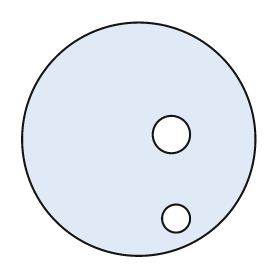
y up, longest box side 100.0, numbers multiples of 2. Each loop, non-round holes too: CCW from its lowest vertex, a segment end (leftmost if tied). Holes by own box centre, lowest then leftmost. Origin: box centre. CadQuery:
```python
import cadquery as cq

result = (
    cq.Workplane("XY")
    .moveTo(0.0, 0.0)
    .circle(50.0)
    .moveTo(16.0, -34.0)
    .circle(6.0)
    .moveTo(14.0, 2.0)
    .circle(8.0)
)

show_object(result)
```